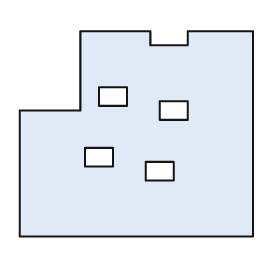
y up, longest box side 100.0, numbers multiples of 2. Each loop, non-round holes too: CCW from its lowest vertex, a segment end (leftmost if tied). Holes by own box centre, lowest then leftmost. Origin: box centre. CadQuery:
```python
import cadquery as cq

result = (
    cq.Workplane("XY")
    .moveTo(-50.0, -44.0)
    .lineTo(50.0, -44.0)
    .lineTo(50.0, 44.0)
    .lineTo(22.0, 44.0)
    .lineTo(22.0, 38.0)
    .lineTo(6.0, 38.0)
    .lineTo(6.0, 44.0)
    .lineTo(-24.0, 44.0)
    .lineTo(-24.0, 10.0)
    .lineTo(-50.0, 10.0)
    .close()
    .moveTo(4.0, -20.0)
    .lineTo(16.0, -20.0)
    .lineTo(16.0, -12.0)
    .lineTo(4.0, -12.0)
    .close()
    .moveTo(-22.0, -14.0)
    .lineTo(-10.0, -14.0)
    .lineTo(-10.0, -6.0)
    .lineTo(-22.0, -6.0)
    .close()
    .moveTo(10.0, 6.0)
    .lineTo(22.0, 6.0)
    .lineTo(22.0, 14.0)
    .lineTo(10.0, 14.0)
    .close()
    .moveTo(-16.0, 12.0)
    .lineTo(-4.0, 12.0)
    .lineTo(-4.0, 20.0)
    .lineTo(-16.0, 20.0)
    .close()
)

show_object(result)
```